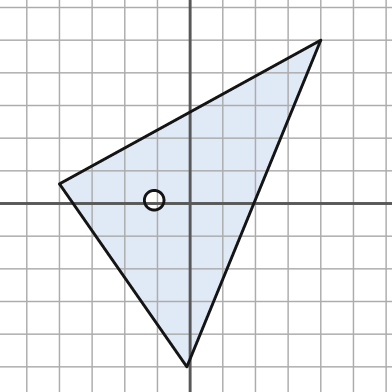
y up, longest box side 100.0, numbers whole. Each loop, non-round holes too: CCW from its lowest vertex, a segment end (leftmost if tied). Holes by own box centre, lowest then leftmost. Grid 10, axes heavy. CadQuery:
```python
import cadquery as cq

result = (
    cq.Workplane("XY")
    .moveTo(-1.0, -50.0)
    .lineTo(40.0, 50.0)
    .lineTo(-40.0, 6.0)
    .close()
    .moveTo(-11.0, 1.0)
    .circle(3.0)
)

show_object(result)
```